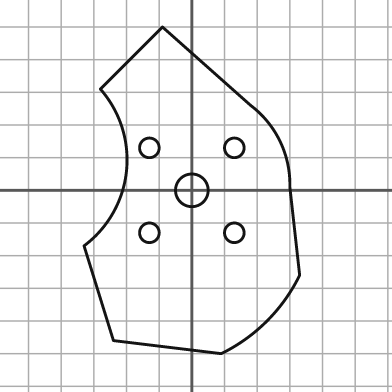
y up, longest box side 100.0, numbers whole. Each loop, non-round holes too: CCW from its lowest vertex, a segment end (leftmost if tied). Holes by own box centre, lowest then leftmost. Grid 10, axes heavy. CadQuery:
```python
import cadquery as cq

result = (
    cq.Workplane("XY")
    .moveTo(9.0, -50.0)
    .threePointArc((23.0, -40.0), (33.0, -26.0))
    .lineTo(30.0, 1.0)
    .threePointArc((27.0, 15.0), (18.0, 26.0))
    .lineTo(-9.0, 50.0)
    .lineTo(-28.0, 31.0)
    .threePointArc((-20.0, 6.0), (-33.0, -17.0))
    .lineTo(-24.0, -46.0)
    .close()
    .moveTo(-13.0, -13.0)
    .circle(3.0)
    .moveTo(13.0, -13.0)
    .circle(3.0)
    .moveTo(0.0, 0.0)
    .circle(5.0)
    .moveTo(-13.0, 13.0)
    .circle(3.0)
    .moveTo(13.0, 13.0)
    .circle(3.0)
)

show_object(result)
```